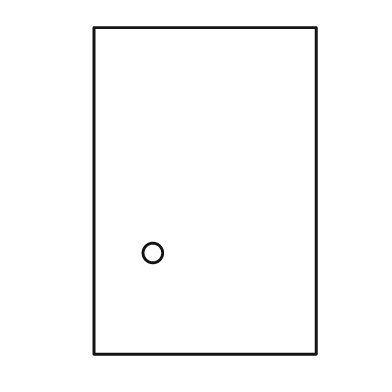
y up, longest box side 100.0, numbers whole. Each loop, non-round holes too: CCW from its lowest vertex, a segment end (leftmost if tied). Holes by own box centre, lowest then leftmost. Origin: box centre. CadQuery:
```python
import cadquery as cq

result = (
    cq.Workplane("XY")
    .moveTo(-34.0, -50.0)
    .lineTo(34.0, -50.0)
    .lineTo(34.0, 50.0)
    .lineTo(-34.0, 50.0)
    .close()
    .moveTo(-16.0, -19.0)
    .circle(3.0)
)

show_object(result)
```